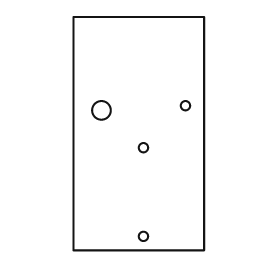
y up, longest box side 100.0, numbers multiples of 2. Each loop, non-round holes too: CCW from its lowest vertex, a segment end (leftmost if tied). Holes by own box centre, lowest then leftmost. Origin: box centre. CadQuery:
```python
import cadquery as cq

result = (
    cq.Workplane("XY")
    .moveTo(-28.0, -50.0)
    .lineTo(28.0, -50.0)
    .lineTo(28.0, 50.0)
    .lineTo(-28.0, 50.0)
    .close()
    .moveTo(2.0, -44.0)
    .circle(2.0)
    .moveTo(2.0, -6.0)
    .circle(2.0)
    .moveTo(-16.0, 10.0)
    .circle(4.0)
    .moveTo(20.0, 12.0)
    .circle(2.0)
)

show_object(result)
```